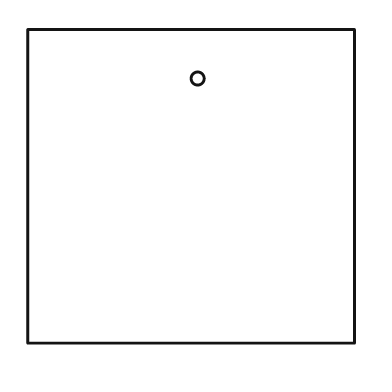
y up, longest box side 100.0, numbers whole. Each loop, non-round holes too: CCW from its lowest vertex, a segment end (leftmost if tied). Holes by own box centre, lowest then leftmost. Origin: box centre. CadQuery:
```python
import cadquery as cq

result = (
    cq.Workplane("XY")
    .moveTo(-50.0, -48.0)
    .lineTo(50.0, -48.0)
    .lineTo(50.0, 48.0)
    .lineTo(-50.0, 48.0)
    .close()
    .moveTo(2.0, 33.0)
    .circle(2.0)
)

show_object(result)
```